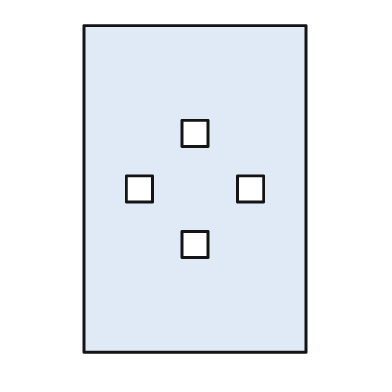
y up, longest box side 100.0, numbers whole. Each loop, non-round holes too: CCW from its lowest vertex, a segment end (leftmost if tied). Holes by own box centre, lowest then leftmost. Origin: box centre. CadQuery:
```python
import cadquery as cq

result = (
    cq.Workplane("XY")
    .moveTo(-34.0, -50.0)
    .lineTo(34.0, -50.0)
    .lineTo(34.0, 50.0)
    .lineTo(-34.0, 50.0)
    .close()
    .moveTo(-4.0, -21.0)
    .lineTo(4.0, -21.0)
    .lineTo(4.0, -13.0)
    .lineTo(-4.0, -13.0)
    .close()
    .moveTo(-21.0, -4.0)
    .lineTo(-13.0, -4.0)
    .lineTo(-13.0, 4.0)
    .lineTo(-21.0, 4.0)
    .close()
    .moveTo(13.0, -4.0)
    .lineTo(21.0, -4.0)
    .lineTo(21.0, 4.0)
    .lineTo(13.0, 4.0)
    .close()
    .moveTo(-4.0, 13.0)
    .lineTo(4.0, 13.0)
    .lineTo(4.0, 21.0)
    .lineTo(-4.0, 21.0)
    .close()
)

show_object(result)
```